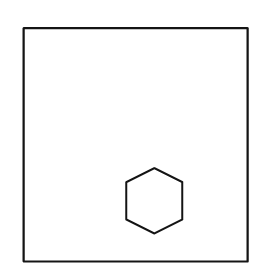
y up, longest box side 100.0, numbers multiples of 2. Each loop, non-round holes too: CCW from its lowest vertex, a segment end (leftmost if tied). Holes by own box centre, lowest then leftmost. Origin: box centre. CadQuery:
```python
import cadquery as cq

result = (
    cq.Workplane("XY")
    .moveTo(-48.0, -50.0)
    .lineTo(48.0, -50.0)
    .lineTo(48.0, 50.0)
    .lineTo(-48.0, 50.0)
    .close()
    .moveTo(8.0, -38.0)
    .lineTo(20.0, -32.0)
    .lineTo(20.0, -16.0)
    .lineTo(8.0, -10.0)
    .lineTo(-4.0, -16.0)
    .lineTo(-4.0, -32.0)
    .close()
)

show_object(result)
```